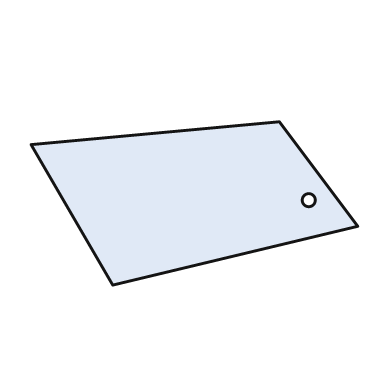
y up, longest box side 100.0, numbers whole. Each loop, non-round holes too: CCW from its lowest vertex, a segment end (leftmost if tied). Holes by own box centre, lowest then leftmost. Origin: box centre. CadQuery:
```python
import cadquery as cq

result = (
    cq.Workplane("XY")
    .moveTo(-25.0, -25.0)
    .lineTo(50.0, -7.0)
    .lineTo(26.0, 25.0)
    .lineTo(-50.0, 18.0)
    .close()
    .moveTo(35.0, 1.0)
    .circle(2.0)
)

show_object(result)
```